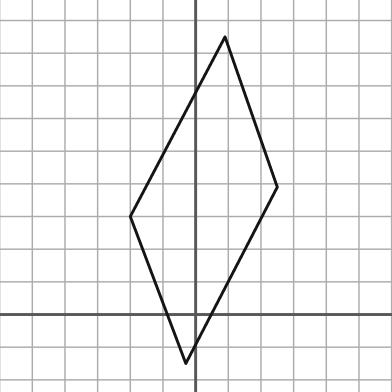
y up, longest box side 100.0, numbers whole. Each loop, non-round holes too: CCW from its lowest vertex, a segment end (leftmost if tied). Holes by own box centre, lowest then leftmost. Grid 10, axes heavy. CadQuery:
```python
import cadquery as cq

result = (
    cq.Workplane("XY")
    .moveTo(-3.0, -15.0)
    .lineTo(25.0, 39.0)
    .lineTo(9.0, 85.0)
    .lineTo(-20.0, 30.0)
    .close()
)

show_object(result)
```